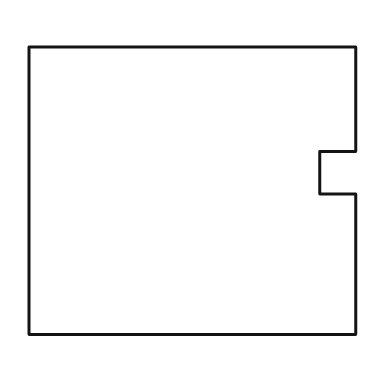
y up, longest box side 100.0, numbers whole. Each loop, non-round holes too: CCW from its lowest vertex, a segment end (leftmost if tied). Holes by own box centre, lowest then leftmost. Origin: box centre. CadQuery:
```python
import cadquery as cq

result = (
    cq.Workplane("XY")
    .moveTo(-50.0, -44.0)
    .lineTo(50.0, -44.0)
    .lineTo(50.0, -1.0)
    .lineTo(39.0, -1.0)
    .lineTo(39.0, 12.0)
    .lineTo(50.0, 12.0)
    .lineTo(50.0, 44.0)
    .lineTo(-50.0, 44.0)
    .close()
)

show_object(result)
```